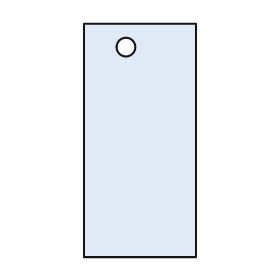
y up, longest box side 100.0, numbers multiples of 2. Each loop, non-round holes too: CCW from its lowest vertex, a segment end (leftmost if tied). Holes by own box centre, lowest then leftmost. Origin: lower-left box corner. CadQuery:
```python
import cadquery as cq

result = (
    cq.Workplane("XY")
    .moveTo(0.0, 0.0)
    .lineTo(48.0, 0.0)
    .lineTo(48.0, 100.0)
    .lineTo(0.0, 100.0)
    .close()
    .moveTo(18.0, 90.0)
    .circle(4.0)
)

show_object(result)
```